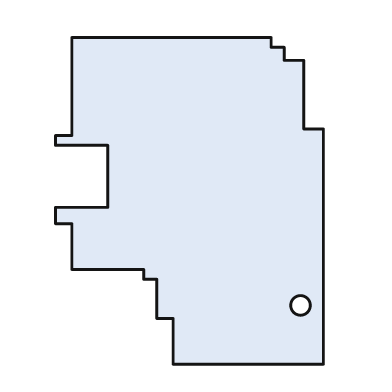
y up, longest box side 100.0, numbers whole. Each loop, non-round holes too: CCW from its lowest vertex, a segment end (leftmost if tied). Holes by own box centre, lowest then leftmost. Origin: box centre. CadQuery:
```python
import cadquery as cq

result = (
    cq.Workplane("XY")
    .moveTo(-5.0, -50.0)
    .lineTo(41.0, -50.0)
    .lineTo(41.0, 22.0)
    .lineTo(35.0, 22.0)
    .lineTo(35.0, 43.0)
    .lineTo(29.0, 43.0)
    .lineTo(29.0, 47.0)
    .lineTo(25.0, 47.0)
    .lineTo(25.0, 50.0)
    .lineTo(-36.0, 50.0)
    .lineTo(-36.0, 20.0)
    .lineTo(-41.0, 20.0)
    .lineTo(-41.0, 17.0)
    .lineTo(-25.0, 17.0)
    .lineTo(-25.0, -2.0)
    .lineTo(-41.0, -2.0)
    .lineTo(-41.0, -7.0)
    .lineTo(-36.0, -7.0)
    .lineTo(-36.0, -21.0)
    .lineTo(-14.0, -21.0)
    .lineTo(-14.0, -24.0)
    .lineTo(-10.0, -24.0)
    .lineTo(-10.0, -36.0)
    .lineTo(-5.0, -36.0)
    .close()
    .moveTo(34.0, -32.0)
    .circle(3.0)
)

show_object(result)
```